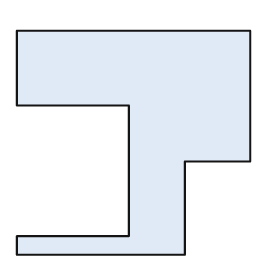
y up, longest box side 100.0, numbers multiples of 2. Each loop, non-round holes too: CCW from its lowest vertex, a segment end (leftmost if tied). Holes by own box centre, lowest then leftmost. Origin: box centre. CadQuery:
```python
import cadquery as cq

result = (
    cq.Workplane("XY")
    .moveTo(-50.0, -48.0)
    .lineTo(22.0, -48.0)
    .lineTo(22.0, -8.0)
    .lineTo(50.0, -8.0)
    .lineTo(50.0, 48.0)
    .lineTo(-50.0, 48.0)
    .lineTo(-50.0, 16.0)
    .lineTo(-2.0, 16.0)
    .lineTo(-2.0, -40.0)
    .lineTo(-50.0, -40.0)
    .close()
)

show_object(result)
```